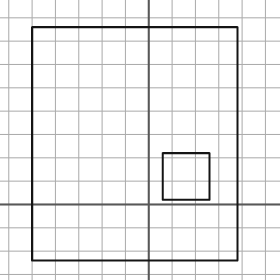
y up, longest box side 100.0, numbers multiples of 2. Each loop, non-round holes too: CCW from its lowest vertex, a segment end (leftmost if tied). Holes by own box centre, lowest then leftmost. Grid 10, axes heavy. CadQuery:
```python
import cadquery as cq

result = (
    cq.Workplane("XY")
    .moveTo(-50.0, -24.0)
    .lineTo(38.0, -24.0)
    .lineTo(38.0, 76.0)
    .lineTo(-50.0, 76.0)
    .close()
    .moveTo(6.0, 2.0)
    .lineTo(26.0, 2.0)
    .lineTo(26.0, 22.0)
    .lineTo(6.0, 22.0)
    .close()
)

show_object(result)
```